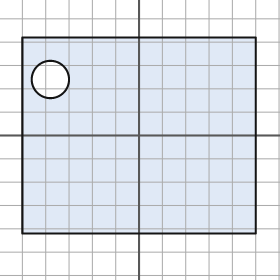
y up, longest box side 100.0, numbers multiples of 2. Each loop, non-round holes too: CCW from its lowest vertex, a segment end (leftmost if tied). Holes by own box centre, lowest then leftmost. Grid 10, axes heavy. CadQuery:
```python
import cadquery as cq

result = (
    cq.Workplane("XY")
    .moveTo(-50.0, -42.0)
    .lineTo(50.0, -42.0)
    .lineTo(50.0, 42.0)
    .lineTo(-50.0, 42.0)
    .close()
    .moveTo(-38.0, 24.0)
    .circle(8.0)
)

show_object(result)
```